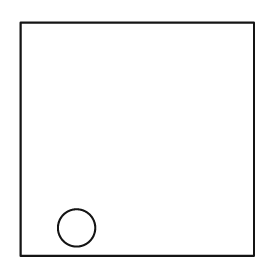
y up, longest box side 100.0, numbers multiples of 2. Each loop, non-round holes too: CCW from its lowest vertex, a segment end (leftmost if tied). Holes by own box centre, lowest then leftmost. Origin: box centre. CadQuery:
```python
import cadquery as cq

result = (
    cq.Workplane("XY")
    .moveTo(-50.0, -50.0)
    .lineTo(50.0, -50.0)
    .lineTo(50.0, 50.0)
    .lineTo(-50.0, 50.0)
    .close()
    .moveTo(-26.0, -38.0)
    .circle(8.0)
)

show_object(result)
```